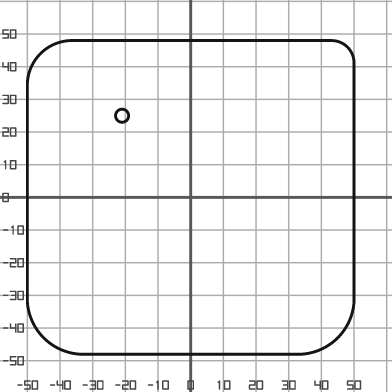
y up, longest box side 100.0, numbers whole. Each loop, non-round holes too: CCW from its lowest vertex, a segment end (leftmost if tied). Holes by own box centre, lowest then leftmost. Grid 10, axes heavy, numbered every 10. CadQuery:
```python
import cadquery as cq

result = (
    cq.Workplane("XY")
    .moveTo(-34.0, -48.0)
    .lineTo(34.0, -48.0)
    .threePointArc((45.0, -43.0), (50.0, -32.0))
    .lineTo(50.0, 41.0)
    .threePointArc((48.0, 46.0), (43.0, 48.0))
    .lineTo(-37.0, 48.0)
    .threePointArc((-46.0, 44.0), (-50.0, 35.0))
    .lineTo(-50.0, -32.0)
    .threePointArc((-45.0, -43.0), (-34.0, -48.0))
    .close()
    .moveTo(-21.0, 25.0)
    .circle(2.0)
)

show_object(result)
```